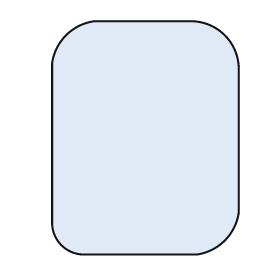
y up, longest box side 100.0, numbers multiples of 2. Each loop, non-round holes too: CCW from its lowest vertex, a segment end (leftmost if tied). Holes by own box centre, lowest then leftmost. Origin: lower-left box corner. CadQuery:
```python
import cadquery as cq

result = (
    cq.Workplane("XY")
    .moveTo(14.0, 0.0)
    .lineTo(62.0, 0.0)
    .threePointArc((74.0, 6.0), (80.0, 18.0))
    .lineTo(80.0, 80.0)
    .threePointArc((74.0, 94.0), (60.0, 100.0))
    .lineTo(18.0, 100.0)
    .threePointArc((6.0, 94.0), (0.0, 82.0))
    .lineTo(0.0, 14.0)
    .threePointArc((4.0, 4.0), (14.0, 0.0))
    .close()
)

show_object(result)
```